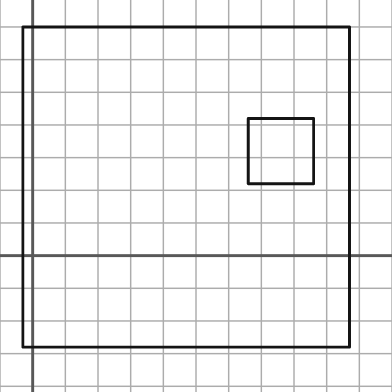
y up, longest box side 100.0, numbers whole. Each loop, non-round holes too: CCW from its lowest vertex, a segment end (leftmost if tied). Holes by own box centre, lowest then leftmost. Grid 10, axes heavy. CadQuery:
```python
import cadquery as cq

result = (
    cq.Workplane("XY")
    .moveTo(-3.0, -28.0)
    .lineTo(97.0, -28.0)
    .lineTo(97.0, 70.0)
    .lineTo(-3.0, 70.0)
    .close()
    .moveTo(66.0, 22.0)
    .lineTo(86.0, 22.0)
    .lineTo(86.0, 42.0)
    .lineTo(66.0, 42.0)
    .close()
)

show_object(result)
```